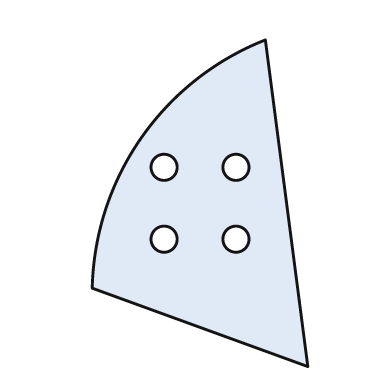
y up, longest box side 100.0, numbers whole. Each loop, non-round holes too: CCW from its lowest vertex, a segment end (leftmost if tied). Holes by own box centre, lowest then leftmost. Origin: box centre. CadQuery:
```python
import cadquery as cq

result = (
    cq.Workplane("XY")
    .moveTo(33.0, -50.0)
    .lineTo(20.0, 50.0)
    .threePointArc((-18.0, 20.0), (-33.0, -26.0))
    .close()
    .moveTo(-11.0, -11.0)
    .circle(4.0)
    .moveTo(11.0, -11.0)
    .circle(4.0)
    .moveTo(-11.0, 11.0)
    .circle(4.0)
    .moveTo(11.0, 11.0)
    .circle(4.0)
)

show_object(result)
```